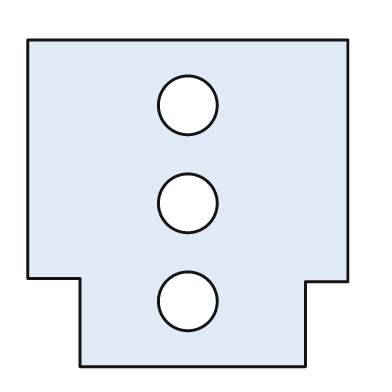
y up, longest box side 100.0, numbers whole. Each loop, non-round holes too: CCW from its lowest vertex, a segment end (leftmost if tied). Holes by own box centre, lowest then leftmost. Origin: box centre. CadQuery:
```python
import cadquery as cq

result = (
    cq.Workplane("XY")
    .moveTo(-33.0, -50.0)
    .lineTo(36.0, -50.0)
    .lineTo(36.0, -24.0)
    .lineTo(49.0, -24.0)
    .lineTo(49.0, 50.0)
    .lineTo(-49.0, 50.0)
    .lineTo(-49.0, -23.0)
    .lineTo(-33.0, -23.0)
    .close()
    .moveTo(0.0, -30.0)
    .circle(9.0)
    .moveTo(0.0, 0.0)
    .circle(9.0)
    .moveTo(0.0, 30.0)
    .circle(9.0)
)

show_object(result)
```